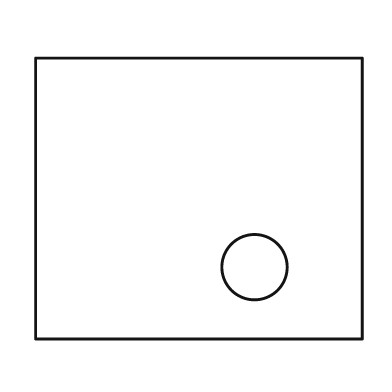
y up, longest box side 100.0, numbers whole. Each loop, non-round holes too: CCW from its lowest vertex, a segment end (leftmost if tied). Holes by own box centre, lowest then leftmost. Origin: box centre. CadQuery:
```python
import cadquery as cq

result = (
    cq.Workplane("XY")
    .moveTo(-50.0, -43.0)
    .lineTo(50.0, -43.0)
    .lineTo(50.0, 43.0)
    .lineTo(-50.0, 43.0)
    .close()
    .moveTo(17.0, -21.0)
    .circle(10.0)
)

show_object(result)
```